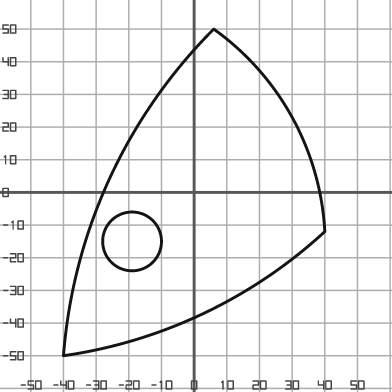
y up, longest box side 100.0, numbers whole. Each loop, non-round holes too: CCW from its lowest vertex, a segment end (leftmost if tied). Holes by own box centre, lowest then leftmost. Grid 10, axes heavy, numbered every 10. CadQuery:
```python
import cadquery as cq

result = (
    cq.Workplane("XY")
    .moveTo(-40.0, -50.0)
    .threePointArc((3.0, -37.0), (40.0, -12.0))
    .threePointArc((30.0, 23.0), (6.0, 50.0))
    .threePointArc((-26.0, 4.0), (-40.0, -50.0))
    .close()
    .moveTo(-19.0, -15.0)
    .circle(9.0)
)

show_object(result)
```